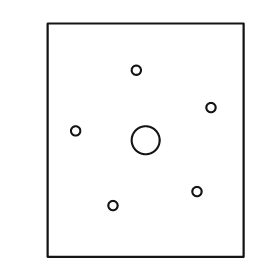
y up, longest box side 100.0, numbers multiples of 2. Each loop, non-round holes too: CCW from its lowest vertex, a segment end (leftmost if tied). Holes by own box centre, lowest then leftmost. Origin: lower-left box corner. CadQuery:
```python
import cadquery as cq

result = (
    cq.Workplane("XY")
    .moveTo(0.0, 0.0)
    .lineTo(84.0, 0.0)
    .lineTo(84.0, 100.0)
    .lineTo(0.0, 100.0)
    .close()
    .moveTo(28.0, 22.0)
    .circle(2.0)
    .moveTo(64.0, 28.0)
    .circle(2.0)
    .moveTo(42.0, 50.0)
    .circle(6.0)
    .moveTo(12.0, 54.0)
    .circle(2.0)
    .moveTo(70.0, 64.0)
    .circle(2.0)
    .moveTo(38.0, 80.0)
    .circle(2.0)
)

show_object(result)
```